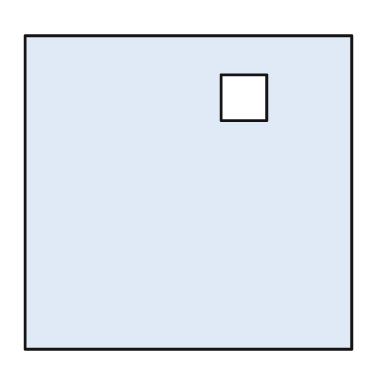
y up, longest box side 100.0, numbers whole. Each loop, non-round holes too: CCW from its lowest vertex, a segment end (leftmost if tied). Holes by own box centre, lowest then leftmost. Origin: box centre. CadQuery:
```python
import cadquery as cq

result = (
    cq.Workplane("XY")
    .moveTo(-50.0, -48.0)
    .lineTo(50.0, -48.0)
    .lineTo(50.0, 48.0)
    .lineTo(-50.0, 48.0)
    .close()
    .moveTo(10.0, 22.0)
    .lineTo(24.0, 22.0)
    .lineTo(24.0, 36.0)
    .lineTo(10.0, 36.0)
    .close()
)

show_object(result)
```